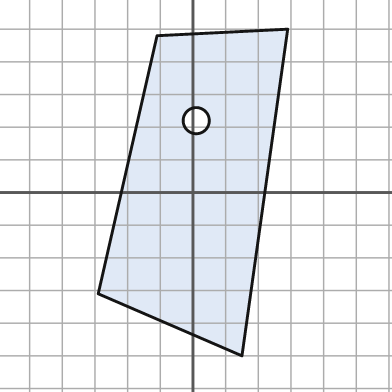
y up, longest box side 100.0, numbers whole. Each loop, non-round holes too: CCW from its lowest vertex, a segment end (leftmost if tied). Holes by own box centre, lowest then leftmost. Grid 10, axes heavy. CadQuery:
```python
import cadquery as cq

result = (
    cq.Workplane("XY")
    .moveTo(15.0, -50.0)
    .lineTo(29.0, 50.0)
    .lineTo(-11.0, 48.0)
    .lineTo(-29.0, -31.0)
    .close()
    .moveTo(1.0, 22.0)
    .circle(4.0)
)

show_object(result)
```